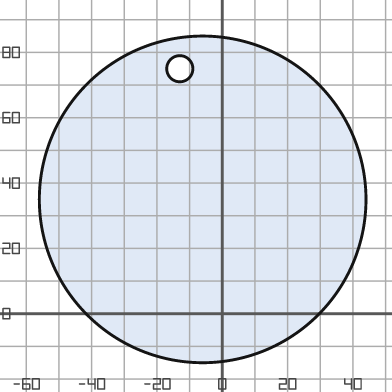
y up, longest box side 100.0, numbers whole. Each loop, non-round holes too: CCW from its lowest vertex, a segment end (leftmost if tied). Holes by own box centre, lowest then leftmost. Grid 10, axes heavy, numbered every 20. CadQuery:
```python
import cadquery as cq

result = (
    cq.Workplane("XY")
    .moveTo(-6.0, 35.0)
    .circle(50.0)
    .moveTo(-13.0, 75.0)
    .circle(4.0)
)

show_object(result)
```